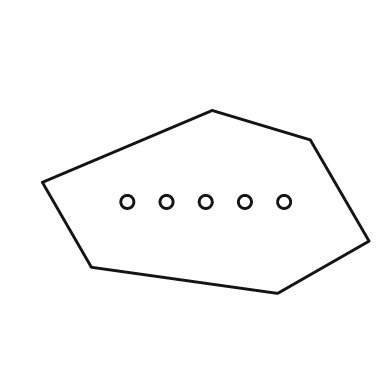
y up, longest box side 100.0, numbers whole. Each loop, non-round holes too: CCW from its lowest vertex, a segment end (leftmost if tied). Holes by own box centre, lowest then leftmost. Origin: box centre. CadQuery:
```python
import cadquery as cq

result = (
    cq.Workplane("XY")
    .moveTo(22.0, -28.0)
    .lineTo(50.0, -12.0)
    .lineTo(32.0, 19.0)
    .lineTo(2.0, 28.0)
    .lineTo(-50.0, 6.0)
    .lineTo(-35.0, -20.0)
    .close()
    .moveTo(-24.0, 0.0)
    .circle(2.0)
    .moveTo(-12.0, 0.0)
    .circle(2.0)
    .moveTo(0.0, 0.0)
    .circle(2.0)
    .moveTo(12.0, 0.0)
    .circle(2.0)
    .moveTo(24.0, 0.0)
    .circle(2.0)
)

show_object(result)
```